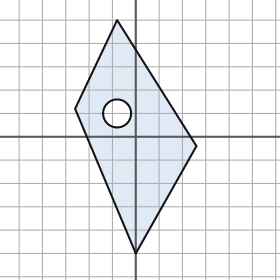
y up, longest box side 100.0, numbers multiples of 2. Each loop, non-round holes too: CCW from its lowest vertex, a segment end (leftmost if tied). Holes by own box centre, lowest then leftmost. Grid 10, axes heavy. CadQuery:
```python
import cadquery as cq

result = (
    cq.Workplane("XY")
    .moveTo(0.0, -50.0)
    .lineTo(26.0, -4.0)
    .lineTo(-8.0, 50.0)
    .lineTo(-26.0, 12.0)
    .close()
    .moveTo(-8.0, 10.0)
    .circle(6.0)
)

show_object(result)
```